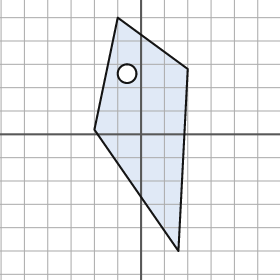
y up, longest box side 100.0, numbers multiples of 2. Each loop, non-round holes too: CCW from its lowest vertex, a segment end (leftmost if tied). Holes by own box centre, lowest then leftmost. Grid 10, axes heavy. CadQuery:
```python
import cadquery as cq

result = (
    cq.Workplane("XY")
    .moveTo(16.0, -50.0)
    .lineTo(20.0, 28.0)
    .lineTo(-10.0, 50.0)
    .lineTo(-20.0, 2.0)
    .close()
    .moveTo(-6.0, 26.0)
    .circle(4.0)
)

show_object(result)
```